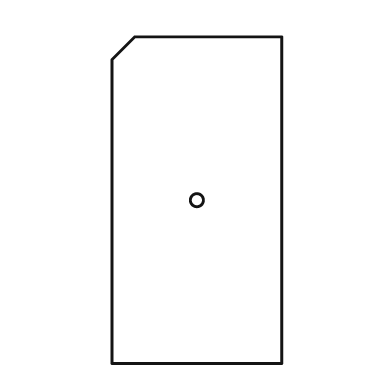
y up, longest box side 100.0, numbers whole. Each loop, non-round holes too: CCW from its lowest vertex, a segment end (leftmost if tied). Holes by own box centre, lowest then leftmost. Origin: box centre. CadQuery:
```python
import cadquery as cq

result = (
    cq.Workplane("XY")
    .moveTo(-26.0, -50.0)
    .lineTo(26.0, -50.0)
    .lineTo(26.0, 50.0)
    .lineTo(-19.0, 50.0)
    .lineTo(-26.0, 43.0)
    .close()
    .moveTo(0.0, 0.0)
    .circle(2.0)
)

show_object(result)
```